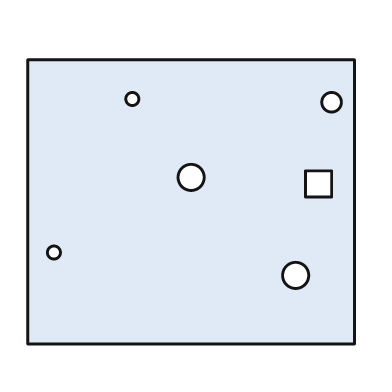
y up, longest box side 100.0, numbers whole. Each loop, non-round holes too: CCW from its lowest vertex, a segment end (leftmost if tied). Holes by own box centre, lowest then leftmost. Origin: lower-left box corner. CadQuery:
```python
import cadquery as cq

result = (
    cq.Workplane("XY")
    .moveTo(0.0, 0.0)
    .lineTo(100.0, 0.0)
    .lineTo(100.0, 87.0)
    .lineTo(0.0, 87.0)
    .close()
    .moveTo(82.0, 21.0)
    .circle(4.0)
    .moveTo(8.0, 28.0)
    .circle(2.0)
    .moveTo(85.0, 45.0)
    .lineTo(93.0, 45.0)
    .lineTo(93.0, 53.0)
    .lineTo(85.0, 53.0)
    .close()
    .moveTo(50.0, 51.0)
    .circle(4.0)
    .moveTo(93.0, 74.0)
    .circle(3.0)
    .moveTo(32.0, 75.0)
    .circle(2.0)
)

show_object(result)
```